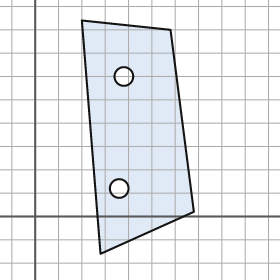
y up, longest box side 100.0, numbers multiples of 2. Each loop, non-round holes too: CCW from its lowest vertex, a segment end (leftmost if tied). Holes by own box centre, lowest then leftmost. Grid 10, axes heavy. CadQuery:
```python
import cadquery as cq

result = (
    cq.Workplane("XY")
    .moveTo(28.0, -16.0)
    .lineTo(68.0, 2.0)
    .lineTo(58.0, 80.0)
    .lineTo(20.0, 84.0)
    .close()
    .moveTo(36.0, 12.0)
    .circle(4.0)
    .moveTo(38.0, 60.0)
    .circle(4.0)
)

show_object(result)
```